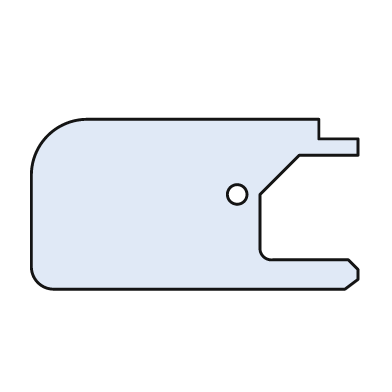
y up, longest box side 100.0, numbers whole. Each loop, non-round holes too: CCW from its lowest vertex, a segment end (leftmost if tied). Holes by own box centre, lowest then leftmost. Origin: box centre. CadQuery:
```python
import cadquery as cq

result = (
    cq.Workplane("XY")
    .moveTo(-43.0, -26.0)
    .lineTo(46.0, -26.0)
    .lineTo(50.0, -23.0)
    .lineTo(50.0, -20.0)
    .lineTo(47.0, -17.0)
    .lineTo(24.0, -17.0)
    .threePointArc((21.0, -16.0), (20.0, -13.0))
    .lineTo(20.0, 3.0)
    .lineTo(32.0, 15.0)
    .lineTo(50.0, 15.0)
    .lineTo(50.0, 20.0)
    .lineTo(38.0, 20.0)
    .lineTo(38.0, 26.0)
    .lineTo(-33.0, 26.0)
    .threePointArc((-45.0, 21.0), (-50.0, 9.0))
    .lineTo(-50.0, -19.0)
    .threePointArc((-48.0, -24.0), (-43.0, -26.0))
    .close()
    .moveTo(13.0, 3.0)
    .circle(3.0)
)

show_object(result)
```